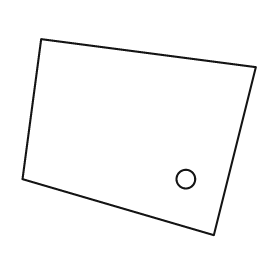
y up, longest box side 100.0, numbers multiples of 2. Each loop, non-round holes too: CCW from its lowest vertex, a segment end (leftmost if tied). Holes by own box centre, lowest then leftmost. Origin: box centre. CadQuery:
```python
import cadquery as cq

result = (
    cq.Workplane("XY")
    .moveTo(32.0, -42.0)
    .lineTo(50.0, 30.0)
    .lineTo(-42.0, 42.0)
    .lineTo(-50.0, -18.0)
    .close()
    .moveTo(20.0, -18.0)
    .circle(4.0)
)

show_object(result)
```